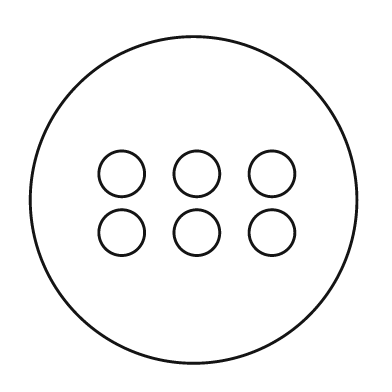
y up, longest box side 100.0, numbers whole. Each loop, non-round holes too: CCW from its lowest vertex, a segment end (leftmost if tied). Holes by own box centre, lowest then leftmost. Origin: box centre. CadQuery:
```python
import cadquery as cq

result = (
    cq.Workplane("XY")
    .moveTo(0.0, 0.0)
    .circle(50.0)
    .moveTo(-22.0, -10.0)
    .circle(7.0)
    .moveTo(1.0, -10.0)
    .circle(7.0)
    .moveTo(24.0, -10.0)
    .circle(7.0)
    .moveTo(-22.0, 8.0)
    .circle(7.0)
    .moveTo(1.0, 8.0)
    .circle(7.0)
    .moveTo(24.0, 8.0)
    .circle(7.0)
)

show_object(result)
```